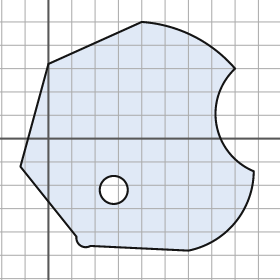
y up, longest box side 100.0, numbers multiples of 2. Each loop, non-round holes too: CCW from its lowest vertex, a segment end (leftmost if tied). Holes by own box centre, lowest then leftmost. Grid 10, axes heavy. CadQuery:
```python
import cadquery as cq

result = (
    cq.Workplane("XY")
    .moveTo(60.0, -48.0)
    .threePointArc((80.0, -36.0), (88.0, -14.0))
    .threePointArc((72.0, 6.0), (80.0, 30.0))
    .threePointArc((62.0, 44.0), (40.0, 50.0))
    .lineTo(0.0, 32.0)
    .lineTo(-12.0, -12.0)
    .lineTo(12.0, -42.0)
    .threePointArc((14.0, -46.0), (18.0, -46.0))
    .close()
    .moveTo(28.0, -22.0)
    .circle(6.0)
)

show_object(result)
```